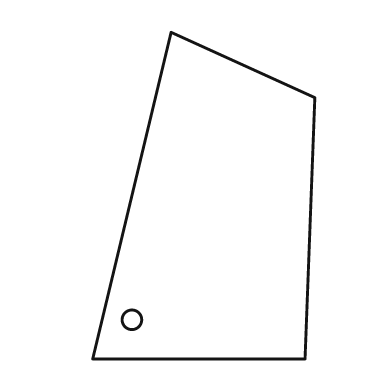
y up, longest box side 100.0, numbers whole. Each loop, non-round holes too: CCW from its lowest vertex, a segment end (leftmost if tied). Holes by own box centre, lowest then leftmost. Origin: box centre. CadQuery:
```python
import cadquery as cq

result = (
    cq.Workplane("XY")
    .moveTo(-34.0, -50.0)
    .lineTo(31.0, -50.0)
    .lineTo(34.0, 30.0)
    .lineTo(-10.0, 50.0)
    .close()
    .moveTo(-22.0, -38.0)
    .circle(3.0)
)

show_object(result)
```